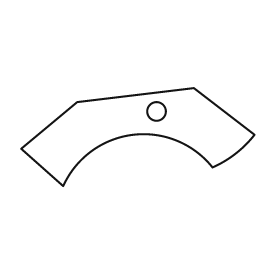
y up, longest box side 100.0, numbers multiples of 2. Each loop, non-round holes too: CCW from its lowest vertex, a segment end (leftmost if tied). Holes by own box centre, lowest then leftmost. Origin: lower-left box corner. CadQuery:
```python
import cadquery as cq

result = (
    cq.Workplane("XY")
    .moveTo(18.0, 0.0)
    .threePointArc((48.0, 22.0), (82.0, 8.0))
    .threePointArc((92.0, 14.0), (100.0, 22.0))
    .lineTo(74.0, 42.0)
    .lineTo(24.0, 36.0)
    .lineTo(0.0, 16.0)
    .close()
    .moveTo(58.0, 32.0)
    .circle(4.0)
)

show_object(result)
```